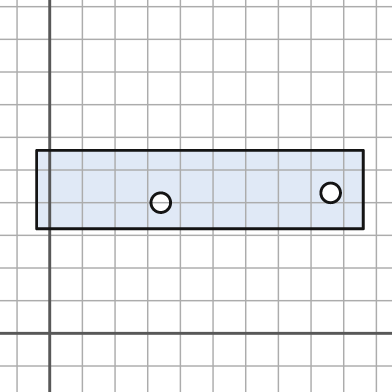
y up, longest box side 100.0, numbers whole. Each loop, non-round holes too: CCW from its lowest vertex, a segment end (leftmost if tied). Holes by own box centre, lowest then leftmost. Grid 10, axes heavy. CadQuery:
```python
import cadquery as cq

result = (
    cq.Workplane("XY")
    .moveTo(-4.0, 32.0)
    .lineTo(96.0, 32.0)
    .lineTo(96.0, 56.0)
    .lineTo(-4.0, 56.0)
    .close()
    .moveTo(34.0, 40.0)
    .circle(3.0)
    .moveTo(86.0, 43.0)
    .circle(3.0)
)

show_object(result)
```